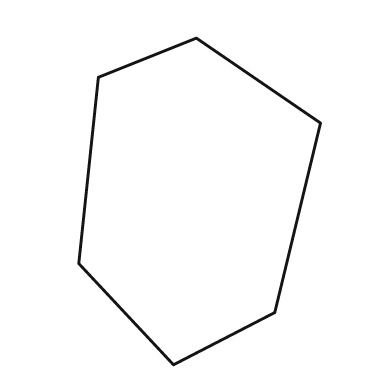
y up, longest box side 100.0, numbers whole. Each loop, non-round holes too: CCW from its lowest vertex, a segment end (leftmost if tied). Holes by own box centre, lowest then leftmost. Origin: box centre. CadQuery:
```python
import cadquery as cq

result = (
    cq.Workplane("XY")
    .moveTo(-8.0, -50.0)
    .lineTo(23.0, -34.0)
    .lineTo(37.0, 24.0)
    .lineTo(-1.0, 50.0)
    .lineTo(-31.0, 38.0)
    .lineTo(-37.0, -19.0)
    .close()
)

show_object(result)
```